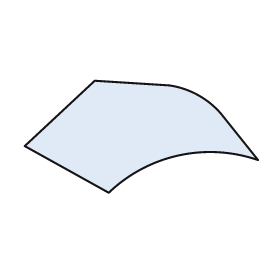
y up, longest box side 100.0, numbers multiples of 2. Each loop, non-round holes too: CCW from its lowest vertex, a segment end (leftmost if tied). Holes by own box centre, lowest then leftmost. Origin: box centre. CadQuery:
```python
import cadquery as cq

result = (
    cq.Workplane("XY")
    .moveTo(-14.0, -24.0)
    .threePointArc((16.0, -8.0), (50.0, -10.0))
    .lineTo(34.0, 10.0)
    .threePointArc((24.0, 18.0), (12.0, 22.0))
    .lineTo(-20.0, 24.0)
    .lineTo(-50.0, -4.0)
    .close()
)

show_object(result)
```